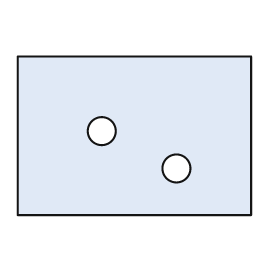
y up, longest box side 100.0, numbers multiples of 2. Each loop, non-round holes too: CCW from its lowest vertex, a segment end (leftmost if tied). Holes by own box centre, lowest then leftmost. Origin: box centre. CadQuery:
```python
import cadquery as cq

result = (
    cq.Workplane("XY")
    .moveTo(-50.0, -34.0)
    .lineTo(50.0, -34.0)
    .lineTo(50.0, 34.0)
    .lineTo(-50.0, 34.0)
    .close()
    .moveTo(18.0, -14.0)
    .circle(6.0)
    .moveTo(-14.0, 2.0)
    .circle(6.0)
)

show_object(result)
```